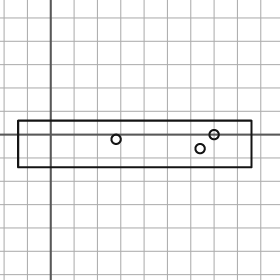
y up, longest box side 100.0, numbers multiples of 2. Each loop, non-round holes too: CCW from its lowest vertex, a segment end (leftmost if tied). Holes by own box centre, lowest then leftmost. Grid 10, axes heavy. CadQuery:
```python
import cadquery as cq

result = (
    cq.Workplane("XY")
    .moveTo(-14.0, -14.0)
    .lineTo(86.0, -14.0)
    .lineTo(86.0, 6.0)
    .lineTo(-14.0, 6.0)
    .close()
    .moveTo(64.0, -6.0)
    .circle(2.0)
    .moveTo(28.0, -2.0)
    .circle(2.0)
    .moveTo(70.0, 0.0)
    .circle(2.0)
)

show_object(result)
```